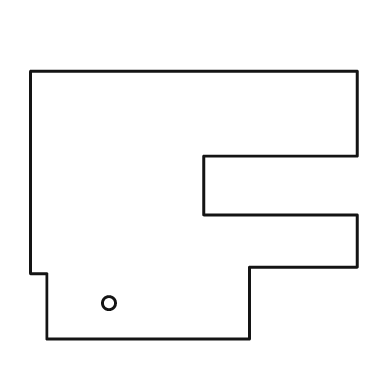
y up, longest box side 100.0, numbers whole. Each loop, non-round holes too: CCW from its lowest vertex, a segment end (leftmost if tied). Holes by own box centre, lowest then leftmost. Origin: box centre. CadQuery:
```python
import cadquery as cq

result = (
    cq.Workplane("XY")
    .moveTo(-45.0, -41.0)
    .lineTo(17.0, -41.0)
    .lineTo(17.0, -19.0)
    .lineTo(50.0, -19.0)
    .lineTo(50.0, -3.0)
    .lineTo(3.0, -3.0)
    .lineTo(3.0, 15.0)
    .lineTo(50.0, 15.0)
    .lineTo(50.0, 41.0)
    .lineTo(-50.0, 41.0)
    .lineTo(-50.0, -21.0)
    .lineTo(-45.0, -21.0)
    .close()
    .moveTo(-26.0, -30.0)
    .circle(2.0)
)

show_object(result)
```